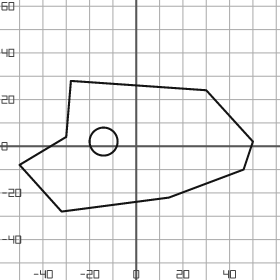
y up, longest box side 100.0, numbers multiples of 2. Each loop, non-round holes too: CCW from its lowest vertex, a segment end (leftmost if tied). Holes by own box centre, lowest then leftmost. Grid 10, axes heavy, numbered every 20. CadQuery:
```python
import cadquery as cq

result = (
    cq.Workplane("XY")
    .moveTo(-32.0, -28.0)
    .lineTo(14.0, -22.0)
    .lineTo(46.0, -10.0)
    .lineTo(50.0, 2.0)
    .lineTo(30.0, 24.0)
    .lineTo(-28.0, 28.0)
    .lineTo(-30.0, 4.0)
    .lineTo(-50.0, -8.0)
    .close()
    .moveTo(-14.0, 2.0)
    .circle(6.0)
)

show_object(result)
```